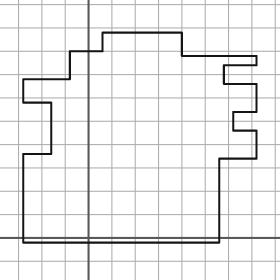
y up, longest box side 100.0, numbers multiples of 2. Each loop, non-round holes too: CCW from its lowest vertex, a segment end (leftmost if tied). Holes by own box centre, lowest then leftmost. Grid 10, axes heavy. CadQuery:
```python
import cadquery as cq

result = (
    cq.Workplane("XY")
    .moveTo(-28.0, -2.0)
    .lineTo(56.0, -2.0)
    .lineTo(56.0, 34.0)
    .lineTo(72.0, 34.0)
    .lineTo(72.0, 46.0)
    .lineTo(62.0, 46.0)
    .lineTo(62.0, 54.0)
    .lineTo(72.0, 54.0)
    .lineTo(72.0, 66.0)
    .lineTo(58.0, 66.0)
    .lineTo(58.0, 74.0)
    .lineTo(72.0, 74.0)
    .lineTo(72.0, 78.0)
    .lineTo(40.0, 78.0)
    .lineTo(40.0, 88.0)
    .lineTo(6.0, 88.0)
    .lineTo(6.0, 80.0)
    .lineTo(-8.0, 80.0)
    .lineTo(-8.0, 68.0)
    .lineTo(-28.0, 68.0)
    .lineTo(-28.0, 58.0)
    .lineTo(-16.0, 58.0)
    .lineTo(-16.0, 36.0)
    .lineTo(-28.0, 36.0)
    .close()
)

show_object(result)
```